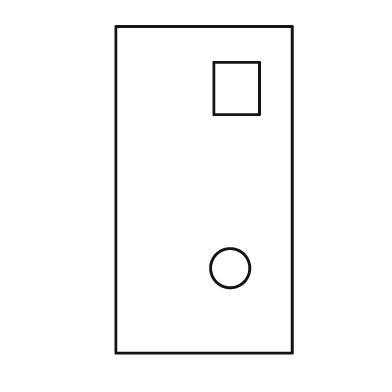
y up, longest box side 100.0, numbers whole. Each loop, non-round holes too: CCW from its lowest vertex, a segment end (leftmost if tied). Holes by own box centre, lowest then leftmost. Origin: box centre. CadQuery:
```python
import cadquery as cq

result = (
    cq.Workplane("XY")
    .moveTo(-27.0, -50.0)
    .lineTo(27.0, -50.0)
    .lineTo(27.0, 50.0)
    .lineTo(-27.0, 50.0)
    .close()
    .moveTo(8.0, -24.0)
    .circle(6.0)
    .moveTo(3.0, 23.0)
    .lineTo(17.0, 23.0)
    .lineTo(17.0, 39.0)
    .lineTo(3.0, 39.0)
    .close()
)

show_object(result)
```